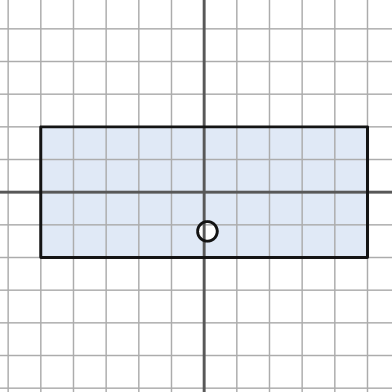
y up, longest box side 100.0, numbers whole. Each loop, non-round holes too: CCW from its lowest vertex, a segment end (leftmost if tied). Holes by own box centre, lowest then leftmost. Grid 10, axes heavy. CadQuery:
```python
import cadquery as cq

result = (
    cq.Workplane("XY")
    .moveTo(-50.0, -20.0)
    .lineTo(50.0, -20.0)
    .lineTo(50.0, 20.0)
    .lineTo(-50.0, 20.0)
    .close()
    .moveTo(1.0, -12.0)
    .circle(3.0)
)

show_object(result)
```